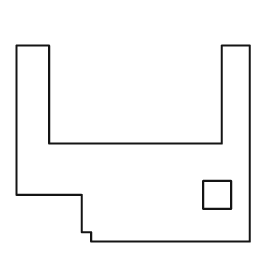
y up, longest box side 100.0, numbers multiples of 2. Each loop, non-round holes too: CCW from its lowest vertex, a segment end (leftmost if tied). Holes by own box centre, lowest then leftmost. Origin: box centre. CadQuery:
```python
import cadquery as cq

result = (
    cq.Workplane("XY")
    .moveTo(-18.0, -42.0)
    .lineTo(50.0, -42.0)
    .lineTo(50.0, 42.0)
    .lineTo(38.0, 42.0)
    .lineTo(38.0, 0.0)
    .lineTo(-36.0, 0.0)
    .lineTo(-36.0, 42.0)
    .lineTo(-50.0, 42.0)
    .lineTo(-50.0, -22.0)
    .lineTo(-22.0, -22.0)
    .lineTo(-22.0, -38.0)
    .lineTo(-18.0, -38.0)
    .close()
    .moveTo(30.0, -28.0)
    .lineTo(42.0, -28.0)
    .lineTo(42.0, -16.0)
    .lineTo(30.0, -16.0)
    .close()
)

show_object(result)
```